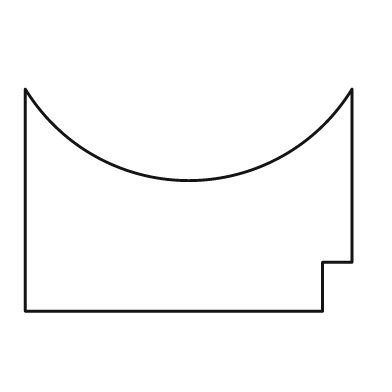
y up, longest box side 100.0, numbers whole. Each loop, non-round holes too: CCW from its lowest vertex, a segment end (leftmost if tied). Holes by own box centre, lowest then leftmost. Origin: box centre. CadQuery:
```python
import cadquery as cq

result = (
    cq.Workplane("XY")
    .moveTo(-50.0, -34.0)
    .lineTo(41.0, -34.0)
    .lineTo(41.0, -19.0)
    .lineTo(50.0, -19.0)
    .lineTo(50.0, 34.0)
    .threePointArc((0.0, 6.0), (-50.0, 34.0))
    .close()
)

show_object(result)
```